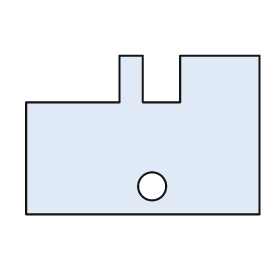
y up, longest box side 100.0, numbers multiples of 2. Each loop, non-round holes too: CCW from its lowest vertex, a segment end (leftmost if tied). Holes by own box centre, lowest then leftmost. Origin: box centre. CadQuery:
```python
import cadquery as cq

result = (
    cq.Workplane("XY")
    .moveTo(-50.0, -34.0)
    .lineTo(50.0, -34.0)
    .lineTo(50.0, 34.0)
    .lineTo(16.0, 34.0)
    .lineTo(16.0, 14.0)
    .lineTo(0.0, 14.0)
    .lineTo(0.0, 34.0)
    .lineTo(-10.0, 34.0)
    .lineTo(-10.0, 14.0)
    .lineTo(-50.0, 14.0)
    .close()
    .moveTo(4.0, -22.0)
    .circle(6.0)
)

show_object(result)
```